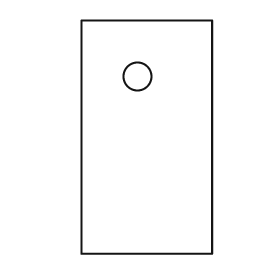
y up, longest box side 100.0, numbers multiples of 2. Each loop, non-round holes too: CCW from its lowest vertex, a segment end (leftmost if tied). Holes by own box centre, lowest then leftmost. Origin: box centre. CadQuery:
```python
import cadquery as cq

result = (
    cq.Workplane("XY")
    .moveTo(-28.0, -50.0)
    .lineTo(28.0, -50.0)
    .lineTo(28.0, 50.0)
    .lineTo(-28.0, 50.0)
    .close()
    .moveTo(-4.0, 26.0)
    .circle(6.0)
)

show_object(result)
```